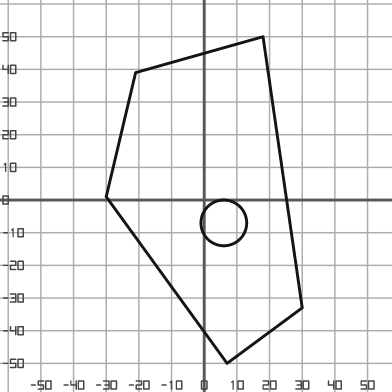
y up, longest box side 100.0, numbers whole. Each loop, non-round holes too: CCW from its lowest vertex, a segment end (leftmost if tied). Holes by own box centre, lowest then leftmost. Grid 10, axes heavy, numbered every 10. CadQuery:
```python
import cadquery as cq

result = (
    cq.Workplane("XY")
    .moveTo(7.0, -50.0)
    .lineTo(30.0, -33.0)
    .lineTo(18.0, 50.0)
    .lineTo(-21.0, 39.0)
    .lineTo(-30.0, 1.0)
    .close()
    .moveTo(6.0, -7.0)
    .circle(7.0)
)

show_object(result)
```